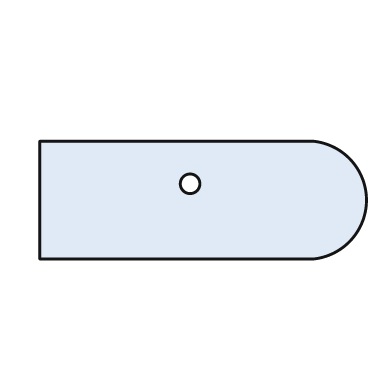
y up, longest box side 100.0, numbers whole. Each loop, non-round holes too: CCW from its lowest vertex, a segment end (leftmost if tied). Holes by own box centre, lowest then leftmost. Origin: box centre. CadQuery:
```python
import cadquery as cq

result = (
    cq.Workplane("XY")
    .moveTo(-50.0, -18.0)
    .lineTo(34.0, -18.0)
    .threePointArc((50.0, 0.0), (34.0, 18.0))
    .lineTo(-50.0, 18.0)
    .close()
    .moveTo(-4.0, 5.0)
    .circle(3.0)
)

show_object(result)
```